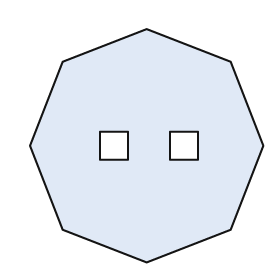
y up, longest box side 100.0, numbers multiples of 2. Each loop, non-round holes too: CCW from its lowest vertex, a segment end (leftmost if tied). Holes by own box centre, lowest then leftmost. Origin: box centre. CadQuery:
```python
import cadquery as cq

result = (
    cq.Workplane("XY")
    .moveTo(0.0, -50.0)
    .lineTo(36.0, -36.0)
    .lineTo(50.0, 0.0)
    .lineTo(36.0, 36.0)
    .lineTo(0.0, 50.0)
    .lineTo(-36.0, 36.0)
    .lineTo(-50.0, 0.0)
    .lineTo(-36.0, -36.0)
    .close()
    .moveTo(-20.0, -6.0)
    .lineTo(-8.0, -6.0)
    .lineTo(-8.0, 6.0)
    .lineTo(-20.0, 6.0)
    .close()
    .moveTo(10.0, -6.0)
    .lineTo(22.0, -6.0)
    .lineTo(22.0, 6.0)
    .lineTo(10.0, 6.0)
    .close()
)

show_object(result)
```